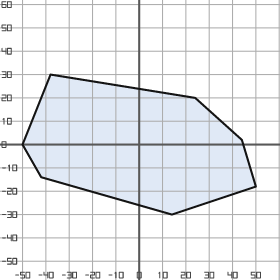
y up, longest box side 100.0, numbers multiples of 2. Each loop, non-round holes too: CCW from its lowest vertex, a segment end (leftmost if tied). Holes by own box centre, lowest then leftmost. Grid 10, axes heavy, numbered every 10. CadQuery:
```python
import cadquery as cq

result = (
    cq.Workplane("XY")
    .moveTo(14.0, -30.0)
    .lineTo(50.0, -18.0)
    .lineTo(44.0, 2.0)
    .lineTo(24.0, 20.0)
    .lineTo(-38.0, 30.0)
    .lineTo(-50.0, 0.0)
    .lineTo(-42.0, -14.0)
    .close()
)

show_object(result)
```